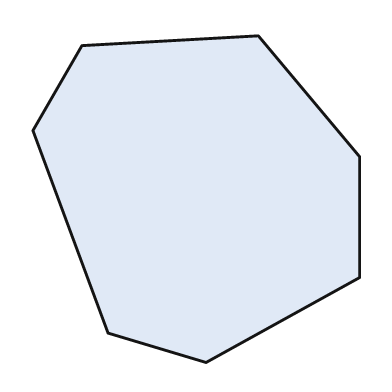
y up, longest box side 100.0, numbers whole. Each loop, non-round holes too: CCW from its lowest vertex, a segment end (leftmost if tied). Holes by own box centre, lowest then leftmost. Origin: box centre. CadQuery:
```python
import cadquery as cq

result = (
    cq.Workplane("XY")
    .moveTo(3.0, -50.0)
    .lineTo(50.0, -24.0)
    .lineTo(50.0, 13.0)
    .lineTo(19.0, 50.0)
    .lineTo(-35.0, 47.0)
    .lineTo(-50.0, 21.0)
    .lineTo(-27.0, -41.0)
    .close()
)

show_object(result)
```